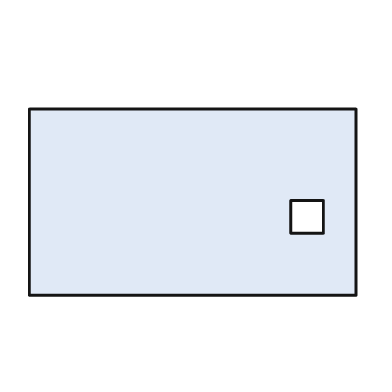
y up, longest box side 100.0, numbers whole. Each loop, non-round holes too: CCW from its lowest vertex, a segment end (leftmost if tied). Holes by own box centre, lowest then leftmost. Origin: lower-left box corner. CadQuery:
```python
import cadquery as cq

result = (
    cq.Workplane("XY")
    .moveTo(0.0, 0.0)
    .lineTo(100.0, 0.0)
    .lineTo(100.0, 57.0)
    .lineTo(0.0, 57.0)
    .close()
    .moveTo(80.0, 19.0)
    .lineTo(90.0, 19.0)
    .lineTo(90.0, 29.0)
    .lineTo(80.0, 29.0)
    .close()
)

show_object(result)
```